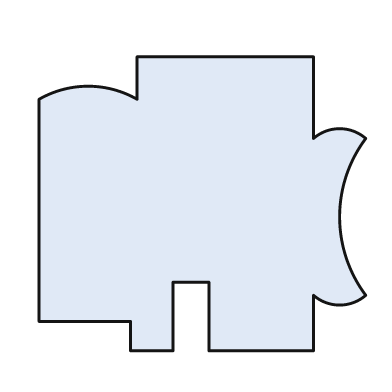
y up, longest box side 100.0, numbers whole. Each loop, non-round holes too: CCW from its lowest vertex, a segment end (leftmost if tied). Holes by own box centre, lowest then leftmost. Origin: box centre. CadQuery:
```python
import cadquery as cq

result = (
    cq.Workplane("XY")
    .moveTo(-22.0, -45.0)
    .lineTo(-9.0, -45.0)
    .lineTo(-9.0, -24.0)
    .lineTo(2.0, -24.0)
    .lineTo(2.0, -45.0)
    .lineTo(34.0, -45.0)
    .lineTo(34.0, -28.0)
    .threePointArc((42.0, -31.0), (50.0, -28.0))
    .threePointArc((42.0, -4.0), (50.0, 20.0))
    .threePointArc((42.0, 23.0), (34.0, 20.0))
    .lineTo(34.0, 45.0)
    .lineTo(-20.0, 45.0)
    .lineTo(-20.0, 32.0)
    .threePointArc((-35.0, 36.0), (-50.0, 32.0))
    .lineTo(-50.0, -36.0)
    .lineTo(-22.0, -36.0)
    .close()
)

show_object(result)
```